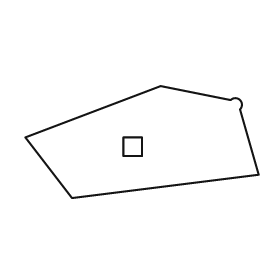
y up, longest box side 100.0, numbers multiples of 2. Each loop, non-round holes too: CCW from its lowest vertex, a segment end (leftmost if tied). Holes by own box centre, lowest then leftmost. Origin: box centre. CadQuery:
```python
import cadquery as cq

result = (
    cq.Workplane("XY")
    .moveTo(-30.0, -24.0)
    .lineTo(50.0, -14.0)
    .lineTo(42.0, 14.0)
    .threePointArc((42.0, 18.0), (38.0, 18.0))
    .lineTo(8.0, 24.0)
    .lineTo(-50.0, 2.0)
    .close()
    .moveTo(-8.0, -6.0)
    .lineTo(0.0, -6.0)
    .lineTo(0.0, 2.0)
    .lineTo(-8.0, 2.0)
    .close()
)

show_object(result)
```